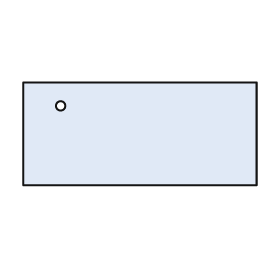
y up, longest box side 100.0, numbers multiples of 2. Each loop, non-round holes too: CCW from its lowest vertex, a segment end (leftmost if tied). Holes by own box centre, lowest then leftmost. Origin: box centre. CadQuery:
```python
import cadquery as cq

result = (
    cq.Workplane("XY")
    .moveTo(-50.0, -22.0)
    .lineTo(50.0, -22.0)
    .lineTo(50.0, 22.0)
    .lineTo(-50.0, 22.0)
    .close()
    .moveTo(-34.0, 12.0)
    .circle(2.0)
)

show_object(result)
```